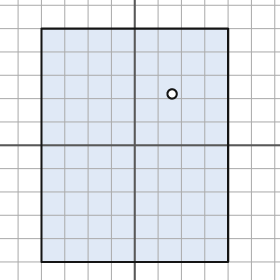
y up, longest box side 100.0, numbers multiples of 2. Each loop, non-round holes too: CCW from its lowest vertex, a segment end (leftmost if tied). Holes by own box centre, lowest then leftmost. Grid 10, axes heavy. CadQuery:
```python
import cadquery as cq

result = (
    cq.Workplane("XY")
    .moveTo(-40.0, -50.0)
    .lineTo(40.0, -50.0)
    .lineTo(40.0, 50.0)
    .lineTo(-40.0, 50.0)
    .close()
    .moveTo(16.0, 22.0)
    .circle(2.0)
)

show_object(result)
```